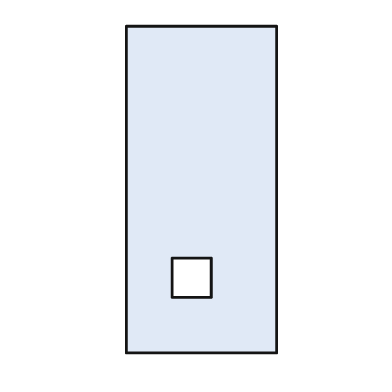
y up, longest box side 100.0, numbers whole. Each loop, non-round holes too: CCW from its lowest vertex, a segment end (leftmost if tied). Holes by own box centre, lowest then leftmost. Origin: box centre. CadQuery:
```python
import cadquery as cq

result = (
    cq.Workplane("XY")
    .moveTo(-23.0, -50.0)
    .lineTo(23.0, -50.0)
    .lineTo(23.0, 50.0)
    .lineTo(-23.0, 50.0)
    .close()
    .moveTo(-9.0, -33.0)
    .lineTo(3.0, -33.0)
    .lineTo(3.0, -21.0)
    .lineTo(-9.0, -21.0)
    .close()
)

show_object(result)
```